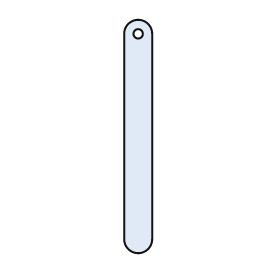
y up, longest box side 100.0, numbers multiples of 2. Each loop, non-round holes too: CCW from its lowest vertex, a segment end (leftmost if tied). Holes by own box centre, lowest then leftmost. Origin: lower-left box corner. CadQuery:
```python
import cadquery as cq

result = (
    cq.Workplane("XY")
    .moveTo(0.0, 6.0)
    .threePointArc((6.0, 0.0), (12.0, 6.0))
    .lineTo(12.0, 94.0)
    .threePointArc((6.0, 100.0), (0.0, 94.0))
    .close()
    .moveTo(6.0, 94.0)
    .circle(2.0)
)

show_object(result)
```